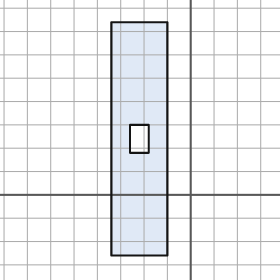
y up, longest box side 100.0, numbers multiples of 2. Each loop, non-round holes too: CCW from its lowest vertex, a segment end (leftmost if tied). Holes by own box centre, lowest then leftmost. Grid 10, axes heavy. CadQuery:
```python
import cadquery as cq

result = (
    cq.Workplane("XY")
    .moveTo(-34.0, -26.0)
    .lineTo(-10.0, -26.0)
    .lineTo(-10.0, 74.0)
    .lineTo(-34.0, 74.0)
    .close()
    .moveTo(-26.0, 18.0)
    .lineTo(-18.0, 18.0)
    .lineTo(-18.0, 30.0)
    .lineTo(-26.0, 30.0)
    .close()
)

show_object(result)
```